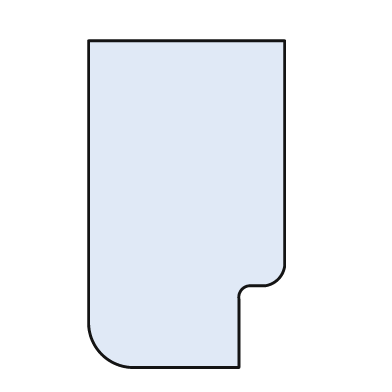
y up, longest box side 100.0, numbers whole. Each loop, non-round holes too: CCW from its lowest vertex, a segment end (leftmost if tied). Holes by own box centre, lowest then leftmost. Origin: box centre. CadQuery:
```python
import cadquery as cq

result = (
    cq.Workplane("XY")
    .moveTo(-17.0, -50.0)
    .lineTo(16.0, -50.0)
    .lineTo(16.0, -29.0)
    .threePointArc((17.0, -26.0), (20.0, -25.0))
    .lineTo(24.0, -25.0)
    .threePointArc((28.0, -23.0), (30.0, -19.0))
    .lineTo(30.0, 50.0)
    .lineTo(-30.0, 50.0)
    .lineTo(-30.0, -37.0)
    .threePointArc((-26.0, -46.0), (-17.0, -50.0))
    .close()
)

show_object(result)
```